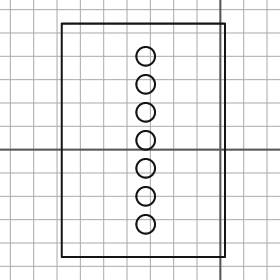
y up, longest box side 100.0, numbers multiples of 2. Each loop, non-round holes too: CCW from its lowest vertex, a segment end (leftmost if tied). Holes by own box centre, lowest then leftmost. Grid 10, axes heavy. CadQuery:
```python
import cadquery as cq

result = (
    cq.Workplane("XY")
    .moveTo(-68.0, -46.0)
    .lineTo(2.0, -46.0)
    .lineTo(2.0, 54.0)
    .lineTo(-68.0, 54.0)
    .close()
    .moveTo(-32.0, -32.0)
    .circle(4.0)
    .moveTo(-32.0, -20.0)
    .circle(4.0)
    .moveTo(-32.0, -8.0)
    .circle(4.0)
    .moveTo(-32.0, 4.0)
    .circle(4.0)
    .moveTo(-32.0, 16.0)
    .circle(4.0)
    .moveTo(-32.0, 28.0)
    .circle(4.0)
    .moveTo(-32.0, 40.0)
    .circle(4.0)
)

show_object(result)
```